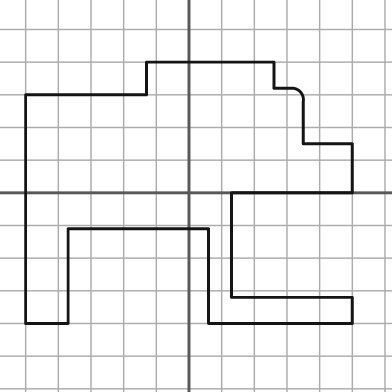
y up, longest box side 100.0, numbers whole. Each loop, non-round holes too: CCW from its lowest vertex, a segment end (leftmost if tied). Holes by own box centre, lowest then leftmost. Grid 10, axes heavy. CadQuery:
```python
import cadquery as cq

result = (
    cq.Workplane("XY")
    .moveTo(-50.0, -40.0)
    .lineTo(-37.0, -40.0)
    .lineTo(-37.0, -11.0)
    .lineTo(6.0, -11.0)
    .lineTo(6.0, -40.0)
    .lineTo(50.0, -40.0)
    .lineTo(50.0, -32.0)
    .lineTo(13.0, -32.0)
    .lineTo(13.0, 0.0)
    .lineTo(50.0, 0.0)
    .lineTo(50.0, 15.0)
    .lineTo(35.0, 15.0)
    .lineTo(35.0, 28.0)
    .threePointArc((34.0, 31.0), (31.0, 32.0))
    .lineTo(26.0, 32.0)
    .lineTo(26.0, 40.0)
    .lineTo(-13.0, 40.0)
    .lineTo(-13.0, 30.0)
    .lineTo(-50.0, 30.0)
    .close()
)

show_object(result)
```